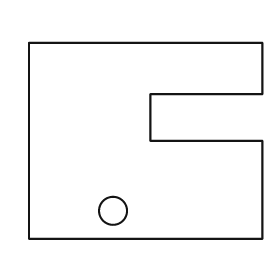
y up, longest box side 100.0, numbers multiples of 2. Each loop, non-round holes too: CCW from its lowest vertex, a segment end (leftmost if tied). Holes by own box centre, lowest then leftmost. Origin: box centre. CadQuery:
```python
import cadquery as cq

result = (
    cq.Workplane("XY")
    .moveTo(-50.0, -42.0)
    .lineTo(50.0, -42.0)
    .lineTo(50.0, 0.0)
    .lineTo(2.0, 0.0)
    .lineTo(2.0, 20.0)
    .lineTo(50.0, 20.0)
    .lineTo(50.0, 42.0)
    .lineTo(-50.0, 42.0)
    .close()
    .moveTo(-14.0, -30.0)
    .circle(6.0)
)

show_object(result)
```